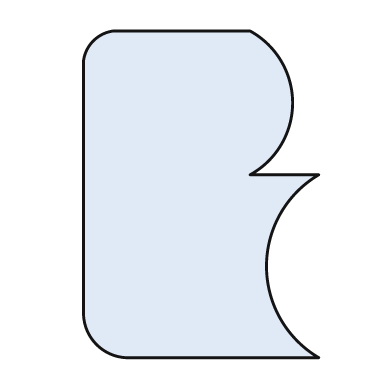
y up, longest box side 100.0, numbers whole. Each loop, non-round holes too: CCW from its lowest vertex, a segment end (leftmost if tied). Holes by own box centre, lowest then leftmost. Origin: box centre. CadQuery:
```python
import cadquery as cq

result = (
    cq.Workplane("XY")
    .moveTo(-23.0, -50.0)
    .lineTo(36.0, -50.0)
    .threePointArc((20.0, -22.0), (36.0, 6.0))
    .lineTo(15.0, 6.0)
    .threePointArc((28.0, 28.0), (15.0, 50.0))
    .lineTo(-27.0, 50.0)
    .threePointArc((-33.0, 47.0), (-36.0, 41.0))
    .lineTo(-36.0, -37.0)
    .threePointArc((-32.0, -46.0), (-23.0, -50.0))
    .close()
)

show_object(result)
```